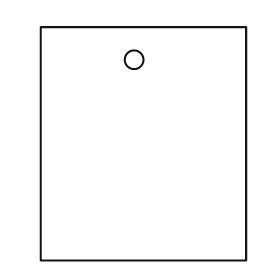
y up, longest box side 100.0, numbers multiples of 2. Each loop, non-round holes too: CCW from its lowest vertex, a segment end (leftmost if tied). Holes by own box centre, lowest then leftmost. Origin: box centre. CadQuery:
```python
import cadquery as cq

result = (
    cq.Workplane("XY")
    .moveTo(-44.0, -50.0)
    .lineTo(44.0, -50.0)
    .lineTo(44.0, 50.0)
    .lineTo(-44.0, 50.0)
    .close()
    .moveTo(-4.0, 36.0)
    .circle(4.0)
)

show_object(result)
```